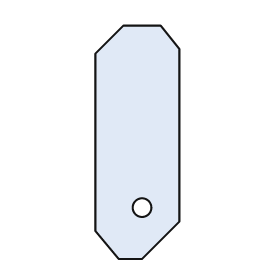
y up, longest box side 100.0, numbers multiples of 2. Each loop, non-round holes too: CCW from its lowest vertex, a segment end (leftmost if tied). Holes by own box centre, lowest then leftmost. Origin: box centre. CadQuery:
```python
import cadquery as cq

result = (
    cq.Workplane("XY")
    .moveTo(-8.0, -50.0)
    .lineTo(2.0, -50.0)
    .lineTo(18.0, -34.0)
    .lineTo(18.0, 40.0)
    .lineTo(10.0, 50.0)
    .lineTo(-6.0, 50.0)
    .lineTo(-18.0, 38.0)
    .lineTo(-18.0, -38.0)
    .close()
    .moveTo(2.0, -28.0)
    .circle(4.0)
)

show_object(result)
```